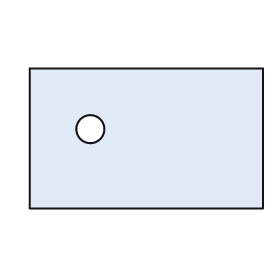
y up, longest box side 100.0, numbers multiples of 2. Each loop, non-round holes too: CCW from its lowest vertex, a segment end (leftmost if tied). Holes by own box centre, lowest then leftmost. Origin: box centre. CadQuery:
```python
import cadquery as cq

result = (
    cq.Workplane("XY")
    .moveTo(-50.0, -30.0)
    .lineTo(50.0, -30.0)
    .lineTo(50.0, 30.0)
    .lineTo(-50.0, 30.0)
    .close()
    .moveTo(-24.0, 4.0)
    .circle(6.0)
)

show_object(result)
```